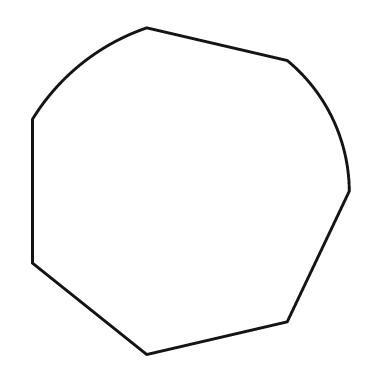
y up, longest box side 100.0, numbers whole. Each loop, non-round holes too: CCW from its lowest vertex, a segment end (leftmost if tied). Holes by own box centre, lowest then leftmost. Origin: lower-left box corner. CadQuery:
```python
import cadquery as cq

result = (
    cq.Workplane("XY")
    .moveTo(35.0, 0.0)
    .lineTo(78.0, 10.0)
    .lineTo(97.0, 50.0)
    .threePointArc((92.0, 72.0), (78.0, 90.0))
    .lineTo(35.0, 100.0)
    .threePointArc((15.0, 89.0), (0.0, 72.0))
    .lineTo(0.0, 28.0)
    .close()
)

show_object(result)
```